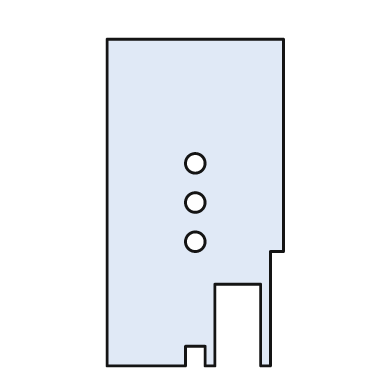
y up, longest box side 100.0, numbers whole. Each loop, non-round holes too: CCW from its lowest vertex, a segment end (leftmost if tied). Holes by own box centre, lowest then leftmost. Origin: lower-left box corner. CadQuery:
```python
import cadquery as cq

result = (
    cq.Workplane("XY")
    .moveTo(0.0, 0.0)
    .lineTo(24.0, 0.0)
    .lineTo(24.0, 6.0)
    .lineTo(30.0, 6.0)
    .lineTo(30.0, 0.0)
    .lineTo(33.0, 0.0)
    .lineTo(33.0, 25.0)
    .lineTo(47.0, 25.0)
    .lineTo(47.0, 0.0)
    .lineTo(50.0, 0.0)
    .lineTo(50.0, 35.0)
    .lineTo(54.0, 35.0)
    .lineTo(54.0, 100.0)
    .lineTo(0.0, 100.0)
    .close()
    .moveTo(27.0, 38.0)
    .circle(3.0)
    .moveTo(27.0, 50.0)
    .circle(3.0)
    .moveTo(27.0, 62.0)
    .circle(3.0)
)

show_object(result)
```